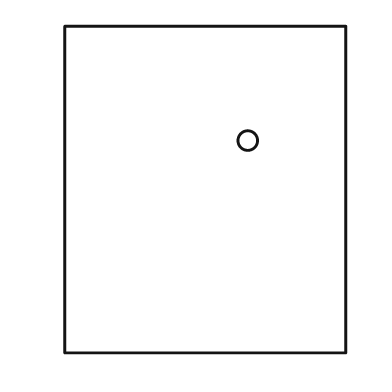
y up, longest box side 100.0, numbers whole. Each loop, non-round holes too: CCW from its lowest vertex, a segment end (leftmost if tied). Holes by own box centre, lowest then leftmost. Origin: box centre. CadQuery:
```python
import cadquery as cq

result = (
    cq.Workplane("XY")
    .moveTo(-43.0, -50.0)
    .lineTo(43.0, -50.0)
    .lineTo(43.0, 50.0)
    .lineTo(-43.0, 50.0)
    .close()
    .moveTo(13.0, 15.0)
    .circle(3.0)
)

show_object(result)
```